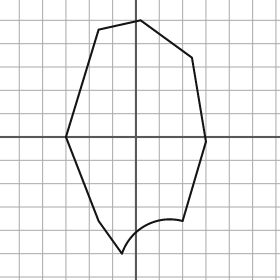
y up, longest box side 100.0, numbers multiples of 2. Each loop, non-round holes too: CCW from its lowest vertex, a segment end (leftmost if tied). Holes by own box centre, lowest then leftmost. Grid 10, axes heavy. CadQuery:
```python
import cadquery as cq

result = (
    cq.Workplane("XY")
    .moveTo(-6.0, -50.0)
    .threePointArc((4.0, -38.0), (20.0, -36.0))
    .lineTo(30.0, -2.0)
    .lineTo(24.0, 34.0)
    .lineTo(2.0, 50.0)
    .lineTo(-16.0, 46.0)
    .lineTo(-30.0, 0.0)
    .lineTo(-16.0, -36.0)
    .close()
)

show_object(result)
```